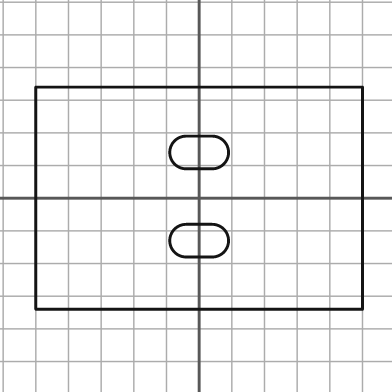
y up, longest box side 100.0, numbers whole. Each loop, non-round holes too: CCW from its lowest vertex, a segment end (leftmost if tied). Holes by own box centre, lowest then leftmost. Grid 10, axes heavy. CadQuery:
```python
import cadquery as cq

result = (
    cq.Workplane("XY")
    .moveTo(-50.0, -34.0)
    .lineTo(50.0, -34.0)
    .lineTo(50.0, 34.0)
    .lineTo(-50.0, 34.0)
    .close()
    .moveTo(-4.0, -18.0)
    .lineTo(4.0, -18.0)
    .threePointArc((9.0, -13.0), (4.0, -8.0))
    .lineTo(-4.0, -8.0)
    .threePointArc((-9.0, -13.0), (-4.0, -18.0))
    .close()
    .moveTo(-4.0, 9.0)
    .lineTo(4.0, 9.0)
    .threePointArc((9.0, 14.0), (4.0, 19.0))
    .lineTo(-4.0, 19.0)
    .threePointArc((-9.0, 14.0), (-4.0, 9.0))
    .close()
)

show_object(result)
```